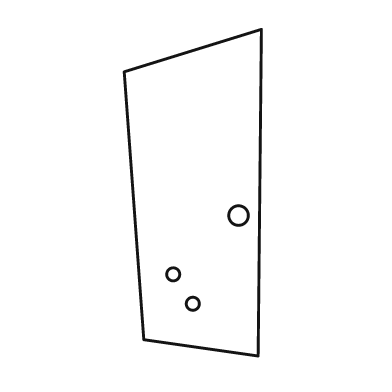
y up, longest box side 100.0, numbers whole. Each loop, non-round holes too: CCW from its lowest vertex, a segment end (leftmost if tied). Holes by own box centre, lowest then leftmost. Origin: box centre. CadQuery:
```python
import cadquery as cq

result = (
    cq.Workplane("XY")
    .moveTo(20.0, -50.0)
    .lineTo(21.0, 50.0)
    .lineTo(-21.0, 37.0)
    .lineTo(-15.0, -45.0)
    .close()
    .moveTo(0.0, -34.0)
    .circle(2.0)
    .moveTo(-6.0, -25.0)
    .circle(2.0)
    .moveTo(14.0, -7.0)
    .circle(3.0)
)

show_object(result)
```